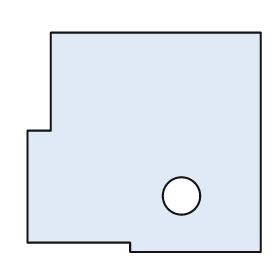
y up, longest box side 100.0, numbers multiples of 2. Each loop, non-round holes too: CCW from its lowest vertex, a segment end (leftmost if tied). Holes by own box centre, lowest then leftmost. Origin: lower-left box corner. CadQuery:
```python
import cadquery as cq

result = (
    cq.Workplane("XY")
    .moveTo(44.0, 0.0)
    .lineTo(100.0, 0.0)
    .lineTo(100.0, 94.0)
    .lineTo(10.0, 94.0)
    .lineTo(10.0, 52.0)
    .lineTo(0.0, 52.0)
    .lineTo(0.0, 4.0)
    .lineTo(44.0, 4.0)
    .close()
    .moveTo(66.0, 24.0)
    .circle(8.0)
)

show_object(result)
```